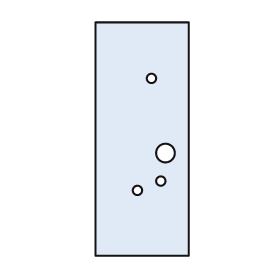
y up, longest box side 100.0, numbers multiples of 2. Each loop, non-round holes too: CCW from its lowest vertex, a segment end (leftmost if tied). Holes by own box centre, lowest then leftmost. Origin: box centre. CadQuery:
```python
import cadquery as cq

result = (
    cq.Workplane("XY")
    .moveTo(-20.0, -50.0)
    .lineTo(20.0, -50.0)
    .lineTo(20.0, 50.0)
    .lineTo(-20.0, 50.0)
    .close()
    .moveTo(-2.0, -22.0)
    .circle(2.0)
    .moveTo(8.0, -18.0)
    .circle(2.0)
    .moveTo(10.0, -6.0)
    .circle(4.0)
    .moveTo(4.0, 26.0)
    .circle(2.0)
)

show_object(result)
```